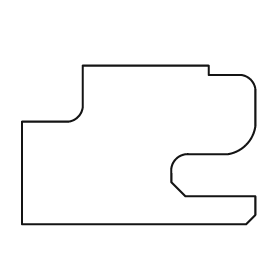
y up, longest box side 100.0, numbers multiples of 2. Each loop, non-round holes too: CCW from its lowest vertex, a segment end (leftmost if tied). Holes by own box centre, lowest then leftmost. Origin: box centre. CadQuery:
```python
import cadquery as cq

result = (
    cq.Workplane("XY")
    .moveTo(-50.0, -34.0)
    .lineTo(46.0, -34.0)
    .lineTo(50.0, -30.0)
    .lineTo(50.0, -22.0)
    .lineTo(20.0, -22.0)
    .lineTo(14.0, -16.0)
    .lineTo(14.0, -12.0)
    .threePointArc((16.0, -6.0), (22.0, -4.0))
    .lineTo(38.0, -4.0)
    .threePointArc((46.0, 0.0), (50.0, 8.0))
    .lineTo(50.0, 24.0)
    .threePointArc((48.0, 28.0), (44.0, 30.0))
    .lineTo(30.0, 30.0)
    .lineTo(30.0, 34.0)
    .lineTo(-24.0, 34.0)
    .lineTo(-24.0, 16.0)
    .threePointArc((-26.0, 12.0), (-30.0, 10.0))
    .lineTo(-50.0, 10.0)
    .close()
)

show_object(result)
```